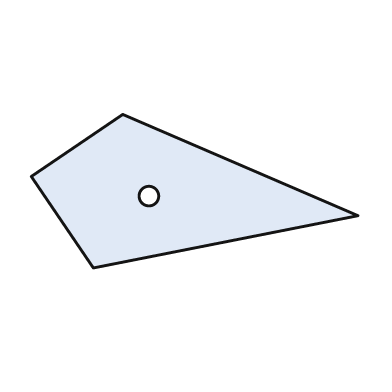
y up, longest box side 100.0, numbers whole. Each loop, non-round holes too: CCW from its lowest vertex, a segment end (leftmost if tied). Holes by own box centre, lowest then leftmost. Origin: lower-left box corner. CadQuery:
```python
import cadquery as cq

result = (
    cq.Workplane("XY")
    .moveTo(19.0, 0.0)
    .lineTo(100.0, 16.0)
    .lineTo(28.0, 47.0)
    .lineTo(0.0, 28.0)
    .close()
    .moveTo(36.0, 22.0)
    .circle(3.0)
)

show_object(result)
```